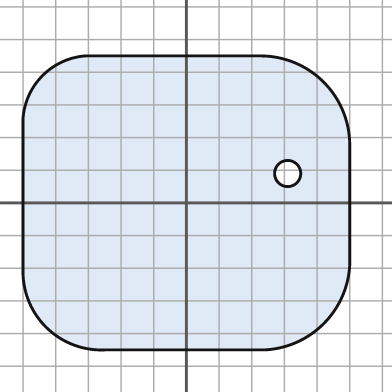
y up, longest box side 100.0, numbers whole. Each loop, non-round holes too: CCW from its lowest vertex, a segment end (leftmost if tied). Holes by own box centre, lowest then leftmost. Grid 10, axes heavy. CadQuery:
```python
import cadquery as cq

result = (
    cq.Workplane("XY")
    .moveTo(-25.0, -45.0)
    .lineTo(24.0, -45.0)
    .threePointArc((42.0, -37.0), (50.0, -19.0))
    .lineTo(50.0, 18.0)
    .threePointArc((42.0, 37.0), (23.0, 45.0))
    .lineTo(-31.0, 45.0)
    .threePointArc((-44.0, 39.0), (-50.0, 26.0))
    .lineTo(-50.0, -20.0)
    .threePointArc((-43.0, -38.0), (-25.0, -45.0))
    .close()
    .moveTo(31.0, 9.0)
    .circle(4.0)
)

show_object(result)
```